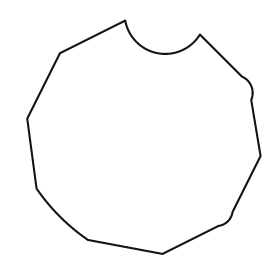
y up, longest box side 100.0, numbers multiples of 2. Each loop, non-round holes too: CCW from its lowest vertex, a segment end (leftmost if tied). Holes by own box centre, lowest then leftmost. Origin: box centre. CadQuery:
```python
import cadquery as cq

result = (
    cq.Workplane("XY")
    .moveTo(8.0, -50.0)
    .lineTo(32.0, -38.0)
    .threePointArc((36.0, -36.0), (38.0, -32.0))
    .lineTo(50.0, -8.0)
    .lineTo(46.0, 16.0)
    .threePointArc((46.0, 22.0), (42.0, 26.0))
    .lineTo(24.0, 44.0)
    .threePointArc((6.0, 36.0), (-8.0, 50.0))
    .lineTo(-36.0, 36.0)
    .lineTo(-50.0, 8.0)
    .lineTo(-46.0, -22.0)
    .threePointArc((-36.0, -34.0), (-24.0, -44.0))
    .close()
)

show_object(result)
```